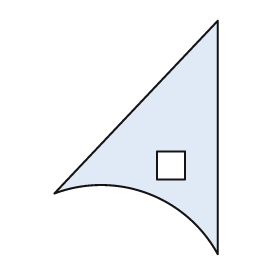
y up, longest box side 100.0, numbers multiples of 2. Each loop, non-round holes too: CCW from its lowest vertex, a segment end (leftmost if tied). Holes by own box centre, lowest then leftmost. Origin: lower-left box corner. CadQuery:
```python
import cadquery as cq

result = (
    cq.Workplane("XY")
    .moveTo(70.0, 0.0)
    .lineTo(70.0, 100.0)
    .lineTo(0.0, 26.0)
    .threePointArc((40.0, 26.0), (70.0, 0.0))
    .close()
    .moveTo(44.0, 32.0)
    .lineTo(56.0, 32.0)
    .lineTo(56.0, 44.0)
    .lineTo(44.0, 44.0)
    .close()
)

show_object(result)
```